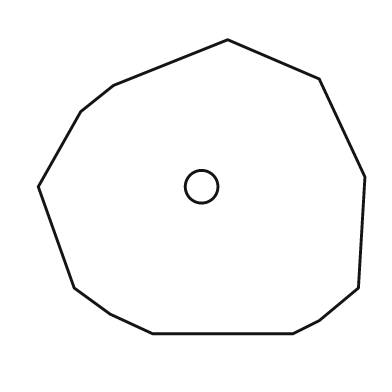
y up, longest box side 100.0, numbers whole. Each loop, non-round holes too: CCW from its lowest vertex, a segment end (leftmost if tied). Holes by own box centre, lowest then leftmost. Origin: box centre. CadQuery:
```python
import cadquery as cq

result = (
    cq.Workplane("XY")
    .moveTo(-15.0, -45.0)
    .lineTo(28.0, -45.0)
    .lineTo(36.0, -41.0)
    .lineTo(48.0, -31.0)
    .lineTo(50.0, 3.0)
    .lineTo(36.0, 33.0)
    .lineTo(8.0, 45.0)
    .lineTo(-27.0, 31.0)
    .lineTo(-37.0, 23.0)
    .lineTo(-50.0, 0.0)
    .lineTo(-39.0, -31.0)
    .lineTo(-28.0, -39.0)
    .close()
    .moveTo(0.0, 0.0)
    .circle(5.0)
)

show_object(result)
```